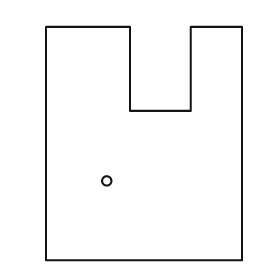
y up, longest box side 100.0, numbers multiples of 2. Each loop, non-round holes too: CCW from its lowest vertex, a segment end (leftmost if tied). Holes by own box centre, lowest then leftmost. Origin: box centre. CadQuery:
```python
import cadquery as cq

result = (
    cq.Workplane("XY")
    .moveTo(-42.0, -50.0)
    .lineTo(42.0, -50.0)
    .lineTo(42.0, 50.0)
    .lineTo(20.0, 50.0)
    .lineTo(20.0, 14.0)
    .lineTo(-6.0, 14.0)
    .lineTo(-6.0, 50.0)
    .lineTo(-42.0, 50.0)
    .close()
    .moveTo(-16.0, -16.0)
    .circle(2.0)
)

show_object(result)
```